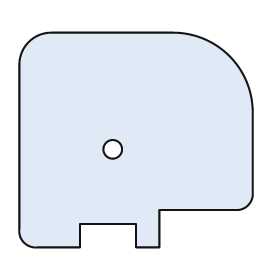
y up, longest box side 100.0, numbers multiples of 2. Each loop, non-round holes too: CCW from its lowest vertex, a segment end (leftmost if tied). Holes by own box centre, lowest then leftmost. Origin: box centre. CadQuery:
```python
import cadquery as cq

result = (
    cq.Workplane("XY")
    .moveTo(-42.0, -46.0)
    .lineTo(-24.0, -46.0)
    .lineTo(-24.0, -36.0)
    .lineTo(0.0, -36.0)
    .lineTo(0.0, -46.0)
    .lineTo(10.0, -46.0)
    .lineTo(10.0, -30.0)
    .lineTo(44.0, -30.0)
    .threePointArc((48.0, -28.0), (50.0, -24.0))
    .lineTo(50.0, 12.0)
    .threePointArc((40.0, 36.0), (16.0, 46.0))
    .lineTo(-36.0, 46.0)
    .threePointArc((-46.0, 42.0), (-50.0, 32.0))
    .lineTo(-50.0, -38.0)
    .threePointArc((-48.0, -44.0), (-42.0, -46.0))
    .close()
    .moveTo(-10.0, -4.0)
    .circle(4.0)
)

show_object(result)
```